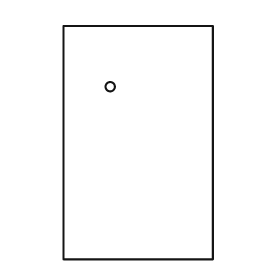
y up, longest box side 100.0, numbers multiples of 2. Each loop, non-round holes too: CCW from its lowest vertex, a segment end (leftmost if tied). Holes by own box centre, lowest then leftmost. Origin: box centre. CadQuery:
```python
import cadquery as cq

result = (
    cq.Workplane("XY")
    .moveTo(-32.0, -50.0)
    .lineTo(32.0, -50.0)
    .lineTo(32.0, 50.0)
    .lineTo(-32.0, 50.0)
    .close()
    .moveTo(-12.0, 24.0)
    .circle(2.0)
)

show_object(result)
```